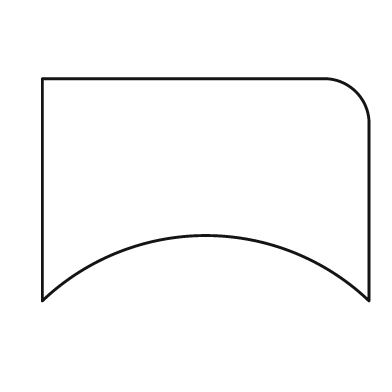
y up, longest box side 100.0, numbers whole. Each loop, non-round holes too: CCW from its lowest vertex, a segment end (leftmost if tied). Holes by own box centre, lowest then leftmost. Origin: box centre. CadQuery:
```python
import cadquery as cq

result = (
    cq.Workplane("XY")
    .moveTo(-50.0, -34.0)
    .threePointArc((0.0, -14.0), (50.0, -34.0))
    .lineTo(50.0, 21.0)
    .threePointArc((46.0, 30.0), (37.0, 34.0))
    .lineTo(-50.0, 34.0)
    .close()
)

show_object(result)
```